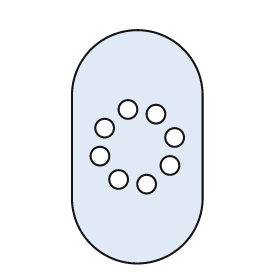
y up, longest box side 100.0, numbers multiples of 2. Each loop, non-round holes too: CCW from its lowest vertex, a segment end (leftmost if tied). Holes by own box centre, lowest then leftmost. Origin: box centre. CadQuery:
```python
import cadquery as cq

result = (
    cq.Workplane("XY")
    .moveTo(-28.0, -22.0)
    .threePointArc((0.0, -50.0), (28.0, -22.0))
    .lineTo(28.0, 22.0)
    .threePointArc((0.0, 50.0), (-28.0, 22.0))
    .close()
    .moveTo(4.0, -16.0)
    .circle(4.0)
    .moveTo(-8.0, -14.0)
    .circle(4.0)
    .moveTo(14.0, -8.0)
    .circle(4.0)
    .moveTo(-16.0, -4.0)
    .circle(4.0)
    .moveTo(16.0, 4.0)
    .circle(4.0)
    .moveTo(-14.0, 8.0)
    .circle(4.0)
    .moveTo(8.0, 14.0)
    .circle(4.0)
    .moveTo(-4.0, 16.0)
    .circle(4.0)
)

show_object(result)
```